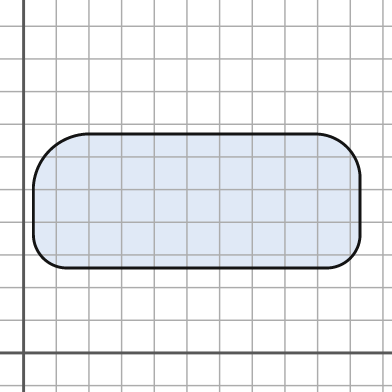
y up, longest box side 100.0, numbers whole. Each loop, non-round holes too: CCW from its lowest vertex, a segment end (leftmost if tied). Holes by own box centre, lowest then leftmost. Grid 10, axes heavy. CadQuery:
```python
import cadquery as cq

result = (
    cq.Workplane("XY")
    .moveTo(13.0, 26.0)
    .lineTo(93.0, 26.0)
    .threePointArc((100.0, 29.0), (103.0, 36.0))
    .lineTo(103.0, 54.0)
    .threePointArc((99.0, 63.0), (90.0, 67.0))
    .lineTo(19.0, 67.0)
    .threePointArc((8.0, 62.0), (3.0, 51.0))
    .lineTo(3.0, 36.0)
    .threePointArc((6.0, 29.0), (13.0, 26.0))
    .close()
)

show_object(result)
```